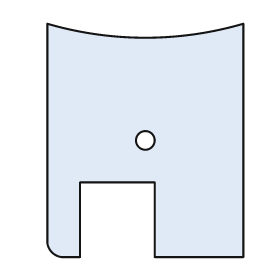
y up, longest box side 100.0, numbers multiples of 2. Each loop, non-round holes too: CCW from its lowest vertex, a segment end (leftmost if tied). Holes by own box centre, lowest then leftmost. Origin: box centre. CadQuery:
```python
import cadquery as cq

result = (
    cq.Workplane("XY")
    .moveTo(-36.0, -50.0)
    .lineTo(-28.0, -50.0)
    .lineTo(-28.0, -18.0)
    .lineTo(4.0, -18.0)
    .lineTo(4.0, -50.0)
    .lineTo(42.0, -50.0)
    .lineTo(42.0, 50.0)
    .threePointArc((0.0, 44.0), (-42.0, 50.0))
    .lineTo(-42.0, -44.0)
    .threePointArc((-40.0, -48.0), (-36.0, -50.0))
    .close()
    .moveTo(0.0, 0.0)
    .circle(4.0)
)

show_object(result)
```